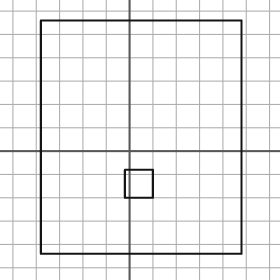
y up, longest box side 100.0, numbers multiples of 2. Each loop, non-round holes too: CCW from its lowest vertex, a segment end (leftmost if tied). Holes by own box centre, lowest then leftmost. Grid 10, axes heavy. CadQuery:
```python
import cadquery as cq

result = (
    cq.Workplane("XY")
    .moveTo(-38.0, -44.0)
    .lineTo(48.0, -44.0)
    .lineTo(48.0, 56.0)
    .lineTo(-38.0, 56.0)
    .close()
    .moveTo(-2.0, -20.0)
    .lineTo(10.0, -20.0)
    .lineTo(10.0, -8.0)
    .lineTo(-2.0, -8.0)
    .close()
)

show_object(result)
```